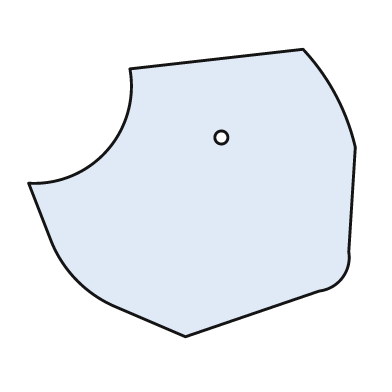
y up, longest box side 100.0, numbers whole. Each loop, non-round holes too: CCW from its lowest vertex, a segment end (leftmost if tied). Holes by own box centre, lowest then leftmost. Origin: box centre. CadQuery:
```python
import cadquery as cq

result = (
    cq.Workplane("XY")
    .moveTo(-2.0, -44.0)
    .lineTo(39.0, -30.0)
    .threePointArc((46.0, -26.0), (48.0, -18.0))
    .lineTo(50.0, 14.0)
    .threePointArc((44.0, 30.0), (34.0, 44.0))
    .lineTo(-19.0, 38.0)
    .threePointArc((-26.0, 13.0), (-50.0, 3.0))
    .lineTo(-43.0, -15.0)
    .threePointArc((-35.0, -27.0), (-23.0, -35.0))
    .close()
    .moveTo(9.0, 17.0)
    .circle(2.0)
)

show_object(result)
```